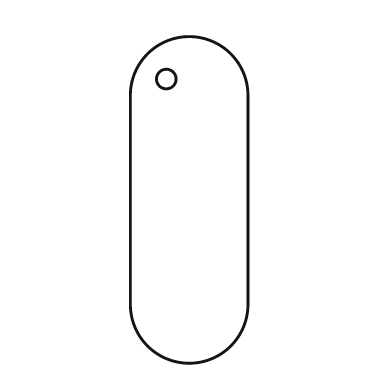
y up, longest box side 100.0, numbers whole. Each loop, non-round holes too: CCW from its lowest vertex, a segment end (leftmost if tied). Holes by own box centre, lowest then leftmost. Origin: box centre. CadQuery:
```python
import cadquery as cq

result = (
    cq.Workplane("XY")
    .moveTo(-18.0, -32.0)
    .threePointArc((0.0, -50.0), (18.0, -32.0))
    .lineTo(18.0, 32.0)
    .threePointArc((0.0, 50.0), (-18.0, 32.0))
    .close()
    .moveTo(-7.0, 37.0)
    .circle(3.0)
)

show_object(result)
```